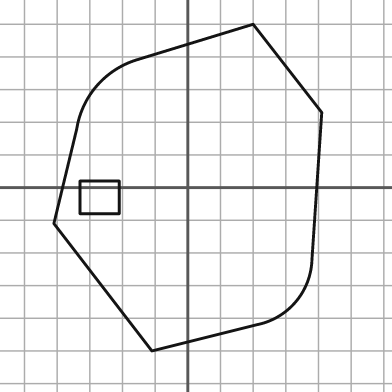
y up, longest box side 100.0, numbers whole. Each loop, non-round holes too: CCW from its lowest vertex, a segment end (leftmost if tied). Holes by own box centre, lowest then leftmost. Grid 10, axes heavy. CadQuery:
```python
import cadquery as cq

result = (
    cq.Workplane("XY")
    .moveTo(-11.0, -50.0)
    .lineTo(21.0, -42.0)
    .threePointArc((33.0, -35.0), (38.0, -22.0))
    .lineTo(41.0, 23.0)
    .lineTo(20.0, 50.0)
    .lineTo(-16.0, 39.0)
    .threePointArc((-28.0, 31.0), (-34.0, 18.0))
    .lineTo(-41.0, -11.0)
    .close()
    .moveTo(-33.0, -8.0)
    .lineTo(-21.0, -8.0)
    .lineTo(-21.0, 2.0)
    .lineTo(-33.0, 2.0)
    .close()
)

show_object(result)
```